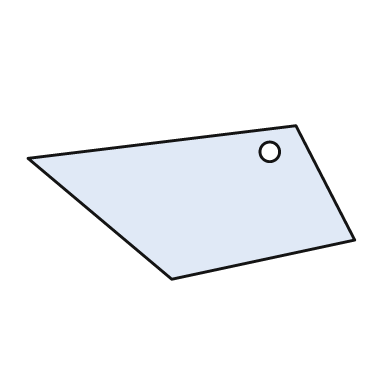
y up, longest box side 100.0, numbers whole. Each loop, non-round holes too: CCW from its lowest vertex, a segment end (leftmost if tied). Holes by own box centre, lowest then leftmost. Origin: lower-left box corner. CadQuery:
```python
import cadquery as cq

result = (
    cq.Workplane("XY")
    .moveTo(44.0, 0.0)
    .lineTo(100.0, 12.0)
    .lineTo(82.0, 47.0)
    .lineTo(0.0, 37.0)
    .close()
    .moveTo(74.0, 39.0)
    .circle(3.0)
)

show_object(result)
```